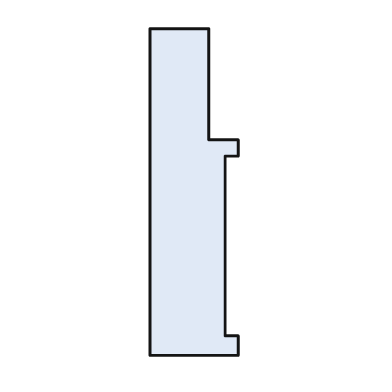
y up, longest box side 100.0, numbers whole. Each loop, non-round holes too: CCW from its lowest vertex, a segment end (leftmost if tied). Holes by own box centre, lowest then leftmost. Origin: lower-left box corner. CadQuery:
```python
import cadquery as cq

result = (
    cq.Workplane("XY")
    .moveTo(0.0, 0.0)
    .lineTo(27.0, 0.0)
    .lineTo(27.0, 6.0)
    .lineTo(23.0, 6.0)
    .lineTo(23.0, 61.0)
    .lineTo(27.0, 61.0)
    .lineTo(27.0, 66.0)
    .lineTo(18.0, 66.0)
    .lineTo(18.0, 100.0)
    .lineTo(0.0, 100.0)
    .close()
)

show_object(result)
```